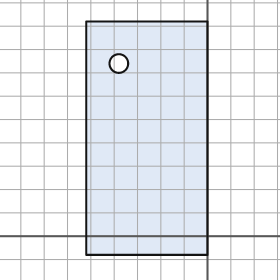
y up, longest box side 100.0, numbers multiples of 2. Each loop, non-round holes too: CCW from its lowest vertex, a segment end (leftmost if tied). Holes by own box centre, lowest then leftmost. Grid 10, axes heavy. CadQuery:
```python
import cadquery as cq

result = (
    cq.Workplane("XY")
    .moveTo(-52.0, -8.0)
    .lineTo(0.0, -8.0)
    .lineTo(0.0, 92.0)
    .lineTo(-52.0, 92.0)
    .close()
    .moveTo(-38.0, 74.0)
    .circle(4.0)
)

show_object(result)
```